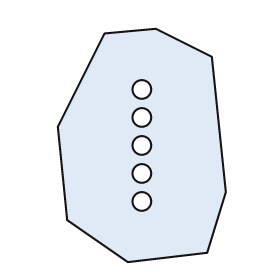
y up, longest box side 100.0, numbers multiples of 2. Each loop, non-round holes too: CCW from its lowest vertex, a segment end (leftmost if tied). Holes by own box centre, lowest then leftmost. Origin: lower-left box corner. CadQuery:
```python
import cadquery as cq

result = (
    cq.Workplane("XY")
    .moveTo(30.0, 0.0)
    .lineTo(64.0, 4.0)
    .lineTo(72.0, 30.0)
    .lineTo(66.0, 88.0)
    .lineTo(42.0, 100.0)
    .lineTo(20.0, 98.0)
    .lineTo(0.0, 58.0)
    .lineTo(4.0, 18.0)
    .close()
    .moveTo(36.0, 26.0)
    .circle(4.0)
    .moveTo(36.0, 38.0)
    .circle(4.0)
    .moveTo(36.0, 50.0)
    .circle(4.0)
    .moveTo(36.0, 62.0)
    .circle(4.0)
    .moveTo(36.0, 74.0)
    .circle(4.0)
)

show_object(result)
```